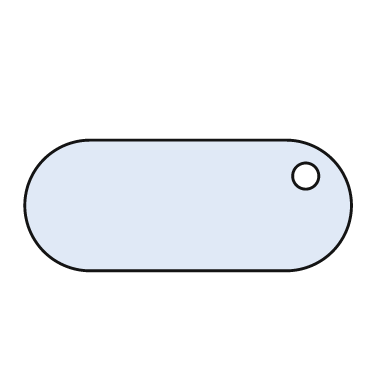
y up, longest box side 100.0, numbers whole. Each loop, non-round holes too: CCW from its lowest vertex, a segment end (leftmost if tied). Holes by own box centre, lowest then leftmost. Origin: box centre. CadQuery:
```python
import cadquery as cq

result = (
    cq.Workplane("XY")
    .moveTo(-30.0, -20.0)
    .lineTo(30.0, -20.0)
    .threePointArc((50.0, 0.0), (30.0, 20.0))
    .lineTo(-30.0, 20.0)
    .threePointArc((-50.0, 0.0), (-30.0, -20.0))
    .close()
    .moveTo(36.0, 9.0)
    .circle(4.0)
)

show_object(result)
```